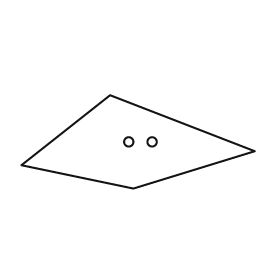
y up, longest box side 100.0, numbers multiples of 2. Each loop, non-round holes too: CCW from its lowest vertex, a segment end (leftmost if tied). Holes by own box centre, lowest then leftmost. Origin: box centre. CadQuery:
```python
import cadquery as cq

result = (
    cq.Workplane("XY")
    .moveTo(-2.0, -20.0)
    .lineTo(50.0, -4.0)
    .lineTo(-12.0, 20.0)
    .lineTo(-50.0, -10.0)
    .close()
    .moveTo(-4.0, 0.0)
    .circle(2.0)
    .moveTo(6.0, 0.0)
    .circle(2.0)
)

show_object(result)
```